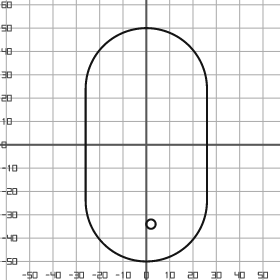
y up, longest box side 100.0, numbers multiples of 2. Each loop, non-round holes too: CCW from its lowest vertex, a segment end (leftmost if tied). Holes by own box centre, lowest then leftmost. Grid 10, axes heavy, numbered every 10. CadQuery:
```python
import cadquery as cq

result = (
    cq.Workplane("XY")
    .moveTo(-26.0, -24.0)
    .threePointArc((0.0, -50.0), (26.0, -24.0))
    .lineTo(26.0, 24.0)
    .threePointArc((0.0, 50.0), (-26.0, 24.0))
    .close()
    .moveTo(2.0, -34.0)
    .circle(2.0)
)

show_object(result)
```